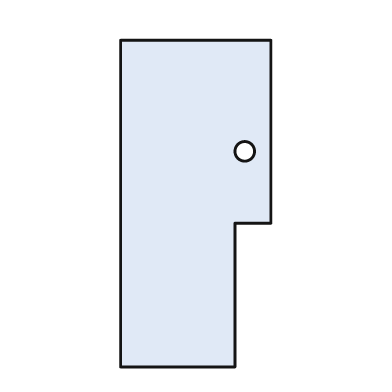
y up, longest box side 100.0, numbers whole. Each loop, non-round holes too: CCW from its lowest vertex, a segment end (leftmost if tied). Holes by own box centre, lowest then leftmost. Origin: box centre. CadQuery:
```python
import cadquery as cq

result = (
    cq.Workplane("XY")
    .moveTo(-23.0, -50.0)
    .lineTo(12.0, -50.0)
    .lineTo(12.0, -6.0)
    .lineTo(23.0, -6.0)
    .lineTo(23.0, 50.0)
    .lineTo(-23.0, 50.0)
    .close()
    .moveTo(15.0, 16.0)
    .circle(3.0)
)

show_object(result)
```